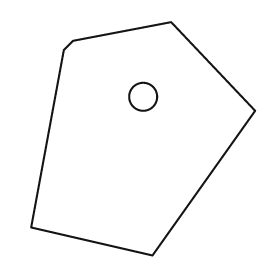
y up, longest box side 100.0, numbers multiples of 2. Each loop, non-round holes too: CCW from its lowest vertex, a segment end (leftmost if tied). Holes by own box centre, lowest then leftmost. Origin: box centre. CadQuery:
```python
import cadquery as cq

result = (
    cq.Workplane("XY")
    .moveTo(4.0, -50.0)
    .lineTo(48.0, 12.0)
    .lineTo(12.0, 50.0)
    .lineTo(-30.0, 42.0)
    .lineTo(-34.0, 38.0)
    .lineTo(-48.0, -38.0)
    .close()
    .moveTo(0.0, 18.0)
    .circle(6.0)
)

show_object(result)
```